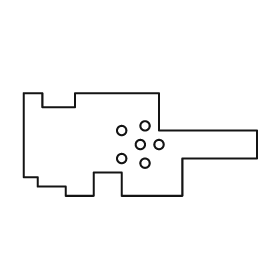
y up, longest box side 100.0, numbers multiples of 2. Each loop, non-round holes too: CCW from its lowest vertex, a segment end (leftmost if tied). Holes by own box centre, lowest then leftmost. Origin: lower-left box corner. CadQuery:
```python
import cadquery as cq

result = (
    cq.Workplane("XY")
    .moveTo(18.0, 0.0)
    .lineTo(30.0, 0.0)
    .lineTo(30.0, 10.0)
    .lineTo(42.0, 10.0)
    .lineTo(42.0, 0.0)
    .lineTo(68.0, 0.0)
    .lineTo(68.0, 16.0)
    .lineTo(100.0, 16.0)
    .lineTo(100.0, 28.0)
    .lineTo(58.0, 28.0)
    .lineTo(58.0, 44.0)
    .lineTo(22.0, 44.0)
    .lineTo(22.0, 38.0)
    .lineTo(8.0, 38.0)
    .lineTo(8.0, 44.0)
    .lineTo(0.0, 44.0)
    .lineTo(0.0, 8.0)
    .lineTo(6.0, 8.0)
    .lineTo(6.0, 4.0)
    .lineTo(18.0, 4.0)
    .close()
    .moveTo(52.0, 14.0)
    .circle(2.0)
    .moveTo(42.0, 16.0)
    .circle(2.0)
    .moveTo(50.0, 22.0)
    .circle(2.0)
    .moveTo(58.0, 22.0)
    .circle(2.0)
    .moveTo(42.0, 28.0)
    .circle(2.0)
    .moveTo(52.0, 30.0)
    .circle(2.0)
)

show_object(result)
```